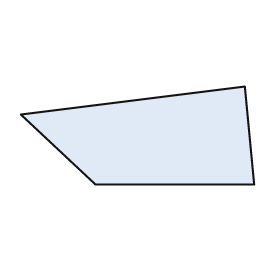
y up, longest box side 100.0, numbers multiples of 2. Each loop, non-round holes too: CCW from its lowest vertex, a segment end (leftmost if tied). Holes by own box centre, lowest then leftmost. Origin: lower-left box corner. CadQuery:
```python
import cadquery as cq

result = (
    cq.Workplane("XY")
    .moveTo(32.0, 0.0)
    .lineTo(100.0, 0.0)
    .lineTo(96.0, 42.0)
    .lineTo(0.0, 30.0)
    .close()
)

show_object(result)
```